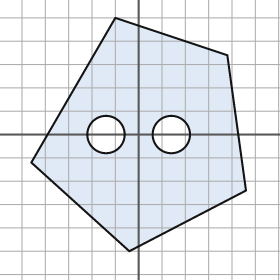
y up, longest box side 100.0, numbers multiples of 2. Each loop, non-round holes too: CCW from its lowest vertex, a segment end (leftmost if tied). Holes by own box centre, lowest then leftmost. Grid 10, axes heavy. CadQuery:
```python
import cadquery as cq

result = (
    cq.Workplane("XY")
    .moveTo(-4.0, -50.0)
    .lineTo(46.0, -24.0)
    .lineTo(38.0, 34.0)
    .lineTo(-10.0, 50.0)
    .lineTo(-46.0, -12.0)
    .close()
    .moveTo(-14.0, 0.0)
    .circle(8.0)
    .moveTo(14.0, 0.0)
    .circle(8.0)
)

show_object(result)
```